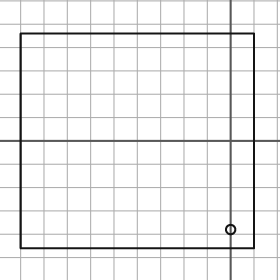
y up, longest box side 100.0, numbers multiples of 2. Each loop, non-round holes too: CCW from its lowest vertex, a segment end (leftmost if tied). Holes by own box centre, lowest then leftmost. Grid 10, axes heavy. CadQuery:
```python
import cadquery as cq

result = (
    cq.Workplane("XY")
    .moveTo(-90.0, -46.0)
    .lineTo(10.0, -46.0)
    .lineTo(10.0, 46.0)
    .lineTo(-90.0, 46.0)
    .close()
    .moveTo(0.0, -38.0)
    .circle(2.0)
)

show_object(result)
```